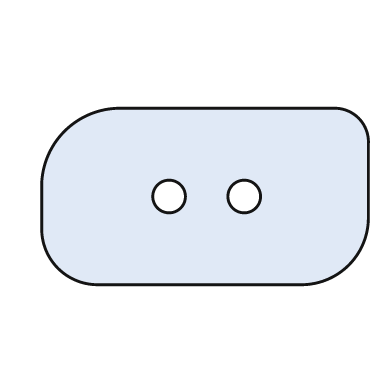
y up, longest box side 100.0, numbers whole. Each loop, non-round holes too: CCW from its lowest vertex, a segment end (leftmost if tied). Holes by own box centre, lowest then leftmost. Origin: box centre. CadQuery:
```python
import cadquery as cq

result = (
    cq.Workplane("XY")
    .moveTo(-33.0, -27.0)
    .lineTo(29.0, -27.0)
    .threePointArc((44.0, -21.0), (50.0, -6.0))
    .lineTo(50.0, 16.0)
    .threePointArc((47.0, 24.0), (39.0, 27.0))
    .lineTo(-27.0, 27.0)
    .threePointArc((-43.0, 20.0), (-50.0, 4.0))
    .lineTo(-50.0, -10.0)
    .threePointArc((-45.0, -22.0), (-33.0, -27.0))
    .close()
    .moveTo(-11.0, 0.0)
    .circle(5.0)
    .moveTo(12.0, 0.0)
    .circle(5.0)
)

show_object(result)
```